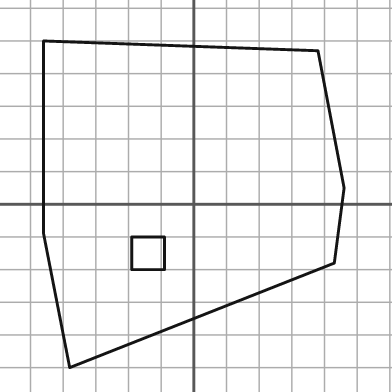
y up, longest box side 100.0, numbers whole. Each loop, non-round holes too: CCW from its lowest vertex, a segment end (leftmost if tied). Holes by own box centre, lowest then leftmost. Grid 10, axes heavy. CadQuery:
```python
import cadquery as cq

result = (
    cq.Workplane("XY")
    .moveTo(-38.0, -50.0)
    .lineTo(43.0, -18.0)
    .lineTo(46.0, 5.0)
    .lineTo(38.0, 47.0)
    .lineTo(-46.0, 50.0)
    .lineTo(-46.0, -9.0)
    .close()
    .moveTo(-19.0, -20.0)
    .lineTo(-9.0, -20.0)
    .lineTo(-9.0, -10.0)
    .lineTo(-19.0, -10.0)
    .close()
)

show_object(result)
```